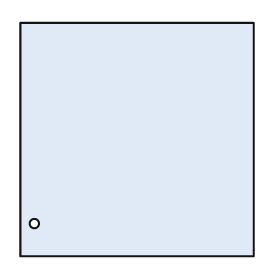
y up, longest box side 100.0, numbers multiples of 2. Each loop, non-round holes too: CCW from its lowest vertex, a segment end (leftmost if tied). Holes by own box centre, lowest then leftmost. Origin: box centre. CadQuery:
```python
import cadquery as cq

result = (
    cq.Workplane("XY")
    .moveTo(-50.0, -50.0)
    .lineTo(50.0, -50.0)
    .lineTo(50.0, 50.0)
    .lineTo(-50.0, 50.0)
    .close()
    .moveTo(-44.0, -36.0)
    .circle(2.0)
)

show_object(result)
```